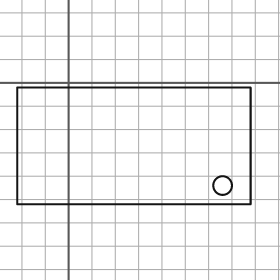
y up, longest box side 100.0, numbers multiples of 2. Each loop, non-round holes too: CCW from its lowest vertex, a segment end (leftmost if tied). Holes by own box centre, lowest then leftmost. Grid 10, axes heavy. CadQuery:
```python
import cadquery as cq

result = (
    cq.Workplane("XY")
    .moveTo(-22.0, -52.0)
    .lineTo(78.0, -52.0)
    .lineTo(78.0, -2.0)
    .lineTo(-22.0, -2.0)
    .close()
    .moveTo(66.0, -44.0)
    .circle(4.0)
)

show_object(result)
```